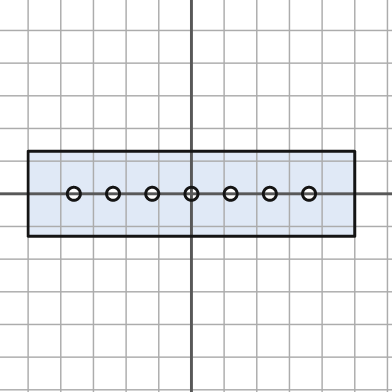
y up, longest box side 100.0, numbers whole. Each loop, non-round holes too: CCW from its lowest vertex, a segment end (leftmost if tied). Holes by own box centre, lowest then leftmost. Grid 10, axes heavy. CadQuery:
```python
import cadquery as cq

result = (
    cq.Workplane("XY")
    .moveTo(-50.0, -13.0)
    .lineTo(50.0, -13.0)
    .lineTo(50.0, 13.0)
    .lineTo(-50.0, 13.0)
    .close()
    .moveTo(-36.0, 0.0)
    .circle(2.0)
    .moveTo(-24.0, 0.0)
    .circle(2.0)
    .moveTo(-12.0, 0.0)
    .circle(2.0)
    .moveTo(0.0, 0.0)
    .circle(2.0)
    .moveTo(12.0, 0.0)
    .circle(2.0)
    .moveTo(24.0, 0.0)
    .circle(2.0)
    .moveTo(36.0, 0.0)
    .circle(2.0)
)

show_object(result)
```